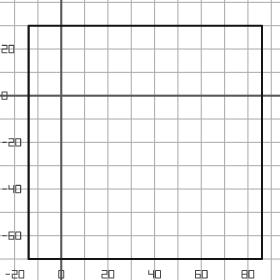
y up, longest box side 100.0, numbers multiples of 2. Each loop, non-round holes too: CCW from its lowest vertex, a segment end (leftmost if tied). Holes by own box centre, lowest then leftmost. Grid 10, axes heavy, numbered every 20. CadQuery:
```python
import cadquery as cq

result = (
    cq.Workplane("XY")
    .moveTo(-14.0, -70.0)
    .lineTo(86.0, -70.0)
    .lineTo(86.0, 30.0)
    .lineTo(-14.0, 30.0)
    .close()
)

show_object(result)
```